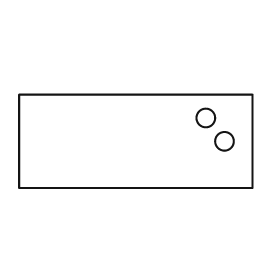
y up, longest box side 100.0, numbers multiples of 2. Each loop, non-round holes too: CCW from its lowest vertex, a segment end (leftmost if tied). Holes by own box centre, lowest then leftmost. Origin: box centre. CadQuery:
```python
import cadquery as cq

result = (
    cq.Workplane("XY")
    .moveTo(-50.0, -20.0)
    .lineTo(50.0, -20.0)
    .lineTo(50.0, 20.0)
    .lineTo(-50.0, 20.0)
    .close()
    .moveTo(38.0, 0.0)
    .circle(4.0)
    .moveTo(30.0, 10.0)
    .circle(4.0)
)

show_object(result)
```